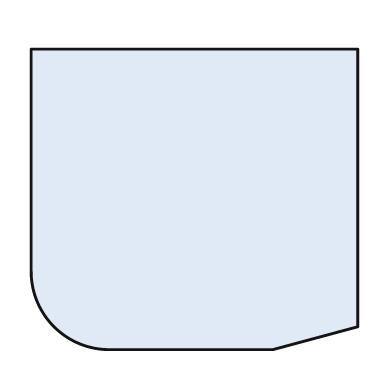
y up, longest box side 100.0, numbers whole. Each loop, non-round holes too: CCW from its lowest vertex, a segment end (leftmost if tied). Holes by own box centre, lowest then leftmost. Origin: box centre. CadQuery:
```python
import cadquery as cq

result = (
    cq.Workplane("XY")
    .moveTo(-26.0, -46.0)
    .lineTo(24.0, -46.0)
    .lineTo(50.0, -39.0)
    .lineTo(50.0, 46.0)
    .lineTo(-50.0, 46.0)
    .lineTo(-50.0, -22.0)
    .threePointArc((-43.0, -39.0), (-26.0, -46.0))
    .close()
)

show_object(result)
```